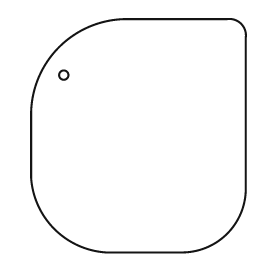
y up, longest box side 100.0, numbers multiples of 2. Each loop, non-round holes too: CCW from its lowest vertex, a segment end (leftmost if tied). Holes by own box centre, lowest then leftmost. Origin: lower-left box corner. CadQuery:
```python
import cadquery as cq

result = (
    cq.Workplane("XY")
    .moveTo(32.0, 0.0)
    .lineTo(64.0, 0.0)
    .threePointArc((84.0, 8.0), (92.0, 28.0))
    .lineTo(92.0, 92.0)
    .threePointArc((90.0, 98.0), (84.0, 100.0))
    .lineTo(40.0, 100.0)
    .threePointArc((12.0, 88.0), (0.0, 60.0))
    .lineTo(0.0, 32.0)
    .threePointArc((10.0, 10.0), (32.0, 0.0))
    .close()
    .moveTo(14.0, 76.0)
    .circle(2.0)
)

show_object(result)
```